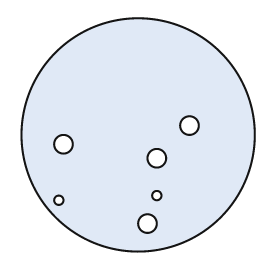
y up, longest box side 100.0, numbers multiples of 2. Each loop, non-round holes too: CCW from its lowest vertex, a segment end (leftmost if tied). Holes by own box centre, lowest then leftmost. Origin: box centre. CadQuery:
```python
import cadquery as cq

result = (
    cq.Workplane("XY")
    .moveTo(0.0, 0.0)
    .circle(50.0)
    .moveTo(4.0, -38.0)
    .circle(4.0)
    .moveTo(-34.0, -28.0)
    .circle(2.0)
    .moveTo(8.0, -26.0)
    .circle(2.0)
    .moveTo(8.0, -10.0)
    .circle(4.0)
    .moveTo(-32.0, -4.0)
    .circle(4.0)
    .moveTo(22.0, 4.0)
    .circle(4.0)
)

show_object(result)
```